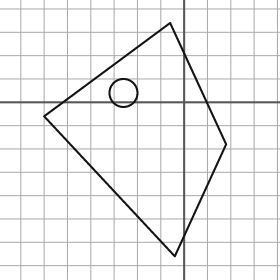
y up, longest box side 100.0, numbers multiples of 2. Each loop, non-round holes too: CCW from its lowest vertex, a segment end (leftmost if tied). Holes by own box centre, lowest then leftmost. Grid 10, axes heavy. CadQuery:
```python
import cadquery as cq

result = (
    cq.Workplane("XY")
    .moveTo(-4.0, -66.0)
    .lineTo(18.0, -18.0)
    .lineTo(-6.0, 34.0)
    .lineTo(-60.0, -6.0)
    .close()
    .moveTo(-26.0, 4.0)
    .circle(6.0)
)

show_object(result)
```